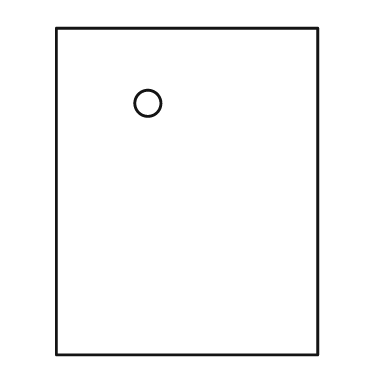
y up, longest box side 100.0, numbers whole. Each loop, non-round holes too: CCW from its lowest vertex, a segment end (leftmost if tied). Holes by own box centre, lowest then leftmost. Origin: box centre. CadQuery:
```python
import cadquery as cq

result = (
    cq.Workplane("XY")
    .moveTo(-40.0, -50.0)
    .lineTo(40.0, -50.0)
    .lineTo(40.0, 50.0)
    .lineTo(-40.0, 50.0)
    .close()
    .moveTo(-12.0, 27.0)
    .circle(4.0)
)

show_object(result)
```